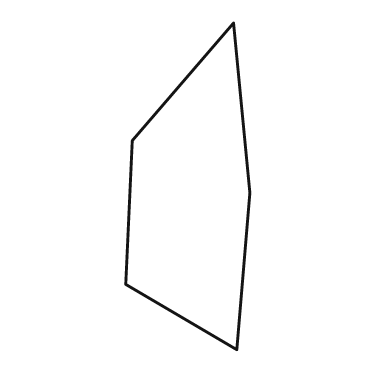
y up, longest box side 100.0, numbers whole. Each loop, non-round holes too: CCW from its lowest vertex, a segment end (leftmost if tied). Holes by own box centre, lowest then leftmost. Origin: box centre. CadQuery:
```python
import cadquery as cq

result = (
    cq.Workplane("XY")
    .moveTo(15.0, -50.0)
    .lineTo(19.0, -2.0)
    .lineTo(14.0, 50.0)
    .lineTo(-17.0, 14.0)
    .lineTo(-19.0, -30.0)
    .close()
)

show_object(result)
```